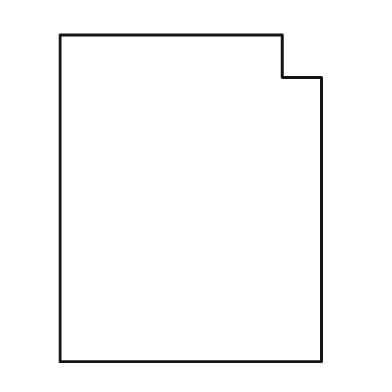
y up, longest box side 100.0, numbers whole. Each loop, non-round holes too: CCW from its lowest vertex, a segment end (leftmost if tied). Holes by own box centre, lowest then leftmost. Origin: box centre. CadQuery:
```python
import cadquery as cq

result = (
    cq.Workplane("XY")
    .moveTo(-40.0, -50.0)
    .lineTo(40.0, -50.0)
    .lineTo(40.0, 37.0)
    .lineTo(28.0, 37.0)
    .lineTo(28.0, 50.0)
    .lineTo(-40.0, 50.0)
    .close()
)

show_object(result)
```